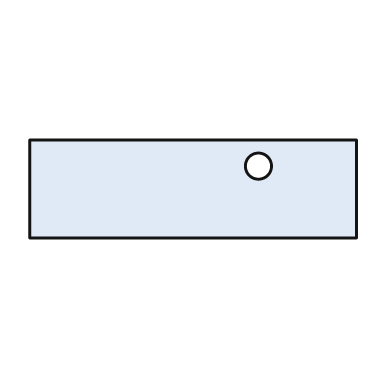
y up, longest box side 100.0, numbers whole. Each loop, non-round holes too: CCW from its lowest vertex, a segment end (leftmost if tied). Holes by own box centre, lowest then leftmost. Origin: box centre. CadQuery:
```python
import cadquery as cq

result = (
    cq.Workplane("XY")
    .moveTo(-50.0, -15.0)
    .lineTo(50.0, -15.0)
    .lineTo(50.0, 15.0)
    .lineTo(-50.0, 15.0)
    .close()
    .moveTo(20.0, 7.0)
    .circle(4.0)
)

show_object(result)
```